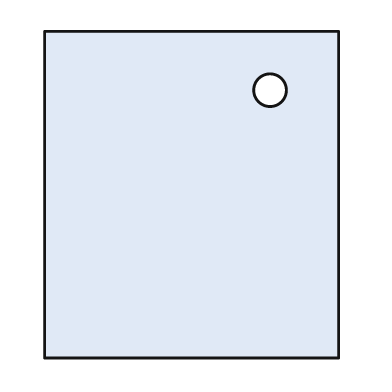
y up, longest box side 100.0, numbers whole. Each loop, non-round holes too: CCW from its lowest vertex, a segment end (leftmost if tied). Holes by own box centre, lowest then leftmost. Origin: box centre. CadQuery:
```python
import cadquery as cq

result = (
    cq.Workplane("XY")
    .moveTo(-45.0, -50.0)
    .lineTo(45.0, -50.0)
    .lineTo(45.0, 50.0)
    .lineTo(-45.0, 50.0)
    .close()
    .moveTo(24.0, 32.0)
    .circle(5.0)
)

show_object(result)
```